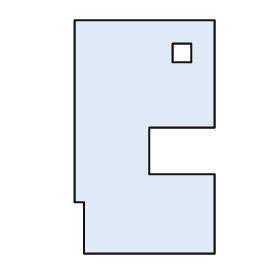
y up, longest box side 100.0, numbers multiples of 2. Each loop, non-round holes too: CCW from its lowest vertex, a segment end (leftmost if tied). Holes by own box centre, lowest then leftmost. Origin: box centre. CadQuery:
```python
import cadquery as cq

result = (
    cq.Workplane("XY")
    .moveTo(-26.0, -50.0)
    .lineTo(30.0, -50.0)
    .lineTo(30.0, -16.0)
    .lineTo(2.0, -16.0)
    .lineTo(2.0, 4.0)
    .lineTo(30.0, 4.0)
    .lineTo(30.0, 50.0)
    .lineTo(-30.0, 50.0)
    .lineTo(-30.0, -28.0)
    .lineTo(-26.0, -28.0)
    .close()
    .moveTo(12.0, 32.0)
    .lineTo(20.0, 32.0)
    .lineTo(20.0, 40.0)
    .lineTo(12.0, 40.0)
    .close()
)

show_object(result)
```